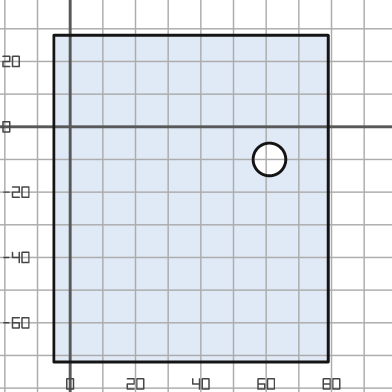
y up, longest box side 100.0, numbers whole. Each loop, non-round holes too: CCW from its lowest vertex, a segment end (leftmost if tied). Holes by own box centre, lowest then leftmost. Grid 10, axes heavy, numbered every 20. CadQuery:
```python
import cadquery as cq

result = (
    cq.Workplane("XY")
    .moveTo(-5.0, -72.0)
    .lineTo(79.0, -72.0)
    .lineTo(79.0, 28.0)
    .lineTo(-5.0, 28.0)
    .close()
    .moveTo(61.0, -10.0)
    .circle(5.0)
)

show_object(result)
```